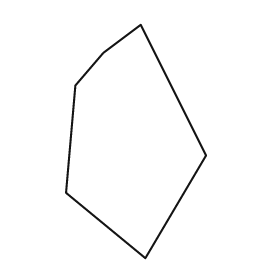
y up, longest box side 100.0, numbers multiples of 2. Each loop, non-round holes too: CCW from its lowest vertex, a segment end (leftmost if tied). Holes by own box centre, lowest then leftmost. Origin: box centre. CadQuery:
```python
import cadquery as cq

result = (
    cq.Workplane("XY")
    .moveTo(4.0, -50.0)
    .lineTo(30.0, -6.0)
    .lineTo(2.0, 50.0)
    .lineTo(-14.0, 38.0)
    .lineTo(-26.0, 24.0)
    .lineTo(-30.0, -22.0)
    .close()
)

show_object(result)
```